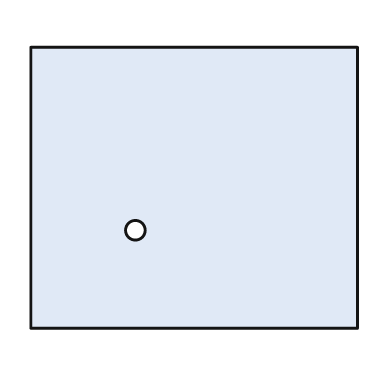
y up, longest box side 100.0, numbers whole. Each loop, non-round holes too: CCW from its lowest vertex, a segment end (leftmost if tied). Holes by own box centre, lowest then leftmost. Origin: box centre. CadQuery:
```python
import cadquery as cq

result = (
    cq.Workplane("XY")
    .moveTo(-50.0, -43.0)
    .lineTo(50.0, -43.0)
    .lineTo(50.0, 43.0)
    .lineTo(-50.0, 43.0)
    .close()
    .moveTo(-18.0, -13.0)
    .circle(3.0)
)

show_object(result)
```